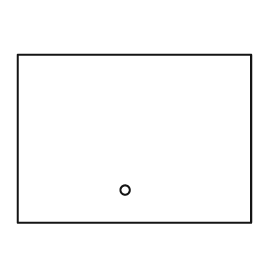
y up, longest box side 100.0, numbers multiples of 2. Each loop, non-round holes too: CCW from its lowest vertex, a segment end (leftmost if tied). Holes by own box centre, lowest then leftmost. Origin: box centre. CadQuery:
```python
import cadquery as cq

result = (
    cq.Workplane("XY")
    .moveTo(-50.0, -36.0)
    .lineTo(50.0, -36.0)
    .lineTo(50.0, 36.0)
    .lineTo(-50.0, 36.0)
    .close()
    .moveTo(-4.0, -22.0)
    .circle(2.0)
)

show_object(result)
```